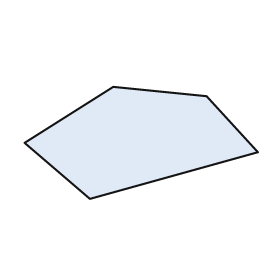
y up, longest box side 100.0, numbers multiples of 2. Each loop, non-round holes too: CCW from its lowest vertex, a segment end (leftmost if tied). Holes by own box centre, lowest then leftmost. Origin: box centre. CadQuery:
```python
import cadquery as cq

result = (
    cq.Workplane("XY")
    .moveTo(-22.0, -24.0)
    .lineTo(50.0, -4.0)
    .lineTo(28.0, 20.0)
    .lineTo(-12.0, 24.0)
    .lineTo(-50.0, 0.0)
    .close()
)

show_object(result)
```